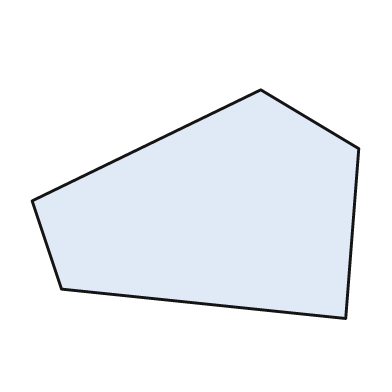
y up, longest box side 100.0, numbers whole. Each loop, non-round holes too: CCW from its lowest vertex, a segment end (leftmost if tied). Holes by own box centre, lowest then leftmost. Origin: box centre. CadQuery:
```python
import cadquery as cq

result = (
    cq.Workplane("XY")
    .moveTo(46.0, -35.0)
    .lineTo(50.0, 17.0)
    .lineTo(20.0, 35.0)
    .lineTo(-50.0, 1.0)
    .lineTo(-41.0, -26.0)
    .close()
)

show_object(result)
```